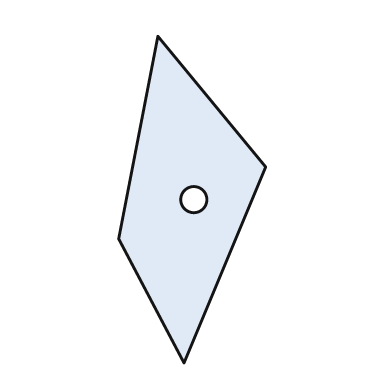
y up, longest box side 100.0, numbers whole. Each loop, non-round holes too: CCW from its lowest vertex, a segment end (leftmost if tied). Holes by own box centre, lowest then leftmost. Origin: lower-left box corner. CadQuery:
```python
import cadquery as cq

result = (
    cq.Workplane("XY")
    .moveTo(20.0, 0.0)
    .lineTo(45.0, 60.0)
    .lineTo(12.0, 100.0)
    .lineTo(0.0, 38.0)
    .close()
    .moveTo(23.0, 50.0)
    .circle(4.0)
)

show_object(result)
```